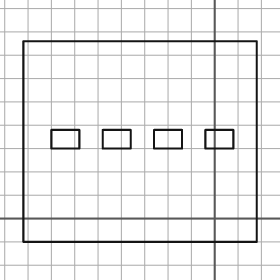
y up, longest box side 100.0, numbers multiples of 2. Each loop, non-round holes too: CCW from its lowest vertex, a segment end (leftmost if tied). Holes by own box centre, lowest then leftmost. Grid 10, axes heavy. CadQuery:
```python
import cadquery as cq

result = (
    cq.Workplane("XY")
    .moveTo(-82.0, -10.0)
    .lineTo(18.0, -10.0)
    .lineTo(18.0, 76.0)
    .lineTo(-82.0, 76.0)
    .close()
    .moveTo(-70.0, 30.0)
    .lineTo(-58.0, 30.0)
    .lineTo(-58.0, 38.0)
    .lineTo(-70.0, 38.0)
    .close()
    .moveTo(-48.0, 30.0)
    .lineTo(-36.0, 30.0)
    .lineTo(-36.0, 38.0)
    .lineTo(-48.0, 38.0)
    .close()
    .moveTo(-26.0, 30.0)
    .lineTo(-14.0, 30.0)
    .lineTo(-14.0, 38.0)
    .lineTo(-26.0, 38.0)
    .close()
    .moveTo(-4.0, 30.0)
    .lineTo(8.0, 30.0)
    .lineTo(8.0, 38.0)
    .lineTo(-4.0, 38.0)
    .close()
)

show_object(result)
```